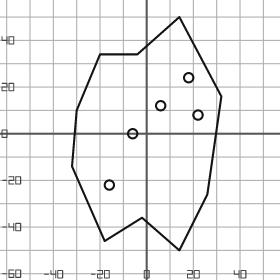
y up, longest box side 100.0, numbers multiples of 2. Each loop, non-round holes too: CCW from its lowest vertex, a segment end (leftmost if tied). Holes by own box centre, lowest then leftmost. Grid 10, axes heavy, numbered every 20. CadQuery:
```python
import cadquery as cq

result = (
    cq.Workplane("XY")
    .moveTo(14.0, -50.0)
    .lineTo(26.0, -26.0)
    .lineTo(32.0, 16.0)
    .lineTo(14.0, 50.0)
    .lineTo(-4.0, 34.0)
    .lineTo(-20.0, 34.0)
    .lineTo(-30.0, 10.0)
    .lineTo(-32.0, -14.0)
    .lineTo(-18.0, -46.0)
    .lineTo(-2.0, -36.0)
    .close()
    .moveTo(-16.0, -22.0)
    .circle(2.0)
    .moveTo(-6.0, 0.0)
    .circle(2.0)
    .moveTo(22.0, 8.0)
    .circle(2.0)
    .moveTo(6.0, 12.0)
    .circle(2.0)
    .moveTo(18.0, 24.0)
    .circle(2.0)
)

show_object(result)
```